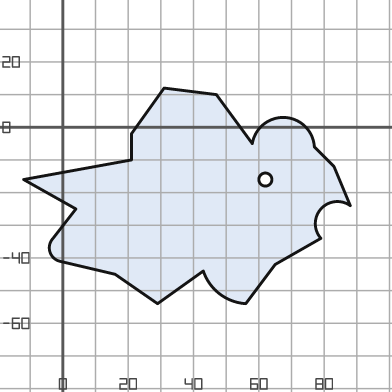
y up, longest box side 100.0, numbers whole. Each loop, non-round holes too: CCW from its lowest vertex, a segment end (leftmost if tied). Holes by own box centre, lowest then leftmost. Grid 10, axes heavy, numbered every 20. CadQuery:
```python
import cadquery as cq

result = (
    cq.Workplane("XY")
    .moveTo(29.0, -54.0)
    .lineTo(43.0, -44.0)
    .threePointArc((48.0, -51.0), (56.0, -54.0))
    .lineTo(65.0, -42.0)
    .lineTo(79.0, -34.0)
    .threePointArc((79.0, -25.0), (88.0, -24.0))
    .lineTo(83.0, -12.0)
    .lineTo(77.0, -6.0)
    .threePointArc((68.0, 3.0), (58.0, -5.0))
    .lineTo(47.0, 10.0)
    .lineTo(31.0, 12.0)
    .lineTo(21.0, -2.0)
    .lineTo(21.0, -10.0)
    .lineTo(-12.0, -16.0)
    .lineTo(4.0, -25.0)
    .lineTo(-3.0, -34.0)
    .threePointArc((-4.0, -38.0), (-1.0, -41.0))
    .lineTo(16.0, -45.0)
    .close()
    .moveTo(62.0, -16.0)
    .circle(2.0)
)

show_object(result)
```